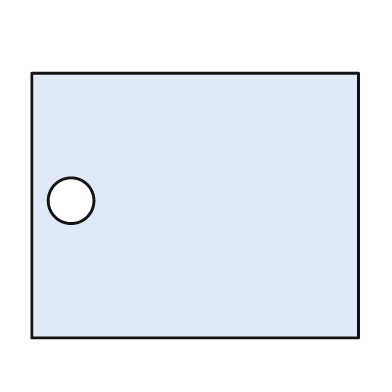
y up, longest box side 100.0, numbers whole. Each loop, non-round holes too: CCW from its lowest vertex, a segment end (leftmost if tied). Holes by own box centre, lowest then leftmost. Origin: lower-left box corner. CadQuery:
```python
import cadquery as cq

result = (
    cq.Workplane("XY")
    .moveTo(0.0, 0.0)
    .lineTo(100.0, 0.0)
    .lineTo(100.0, 81.0)
    .lineTo(0.0, 81.0)
    .close()
    .moveTo(12.0, 42.0)
    .circle(7.0)
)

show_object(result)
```